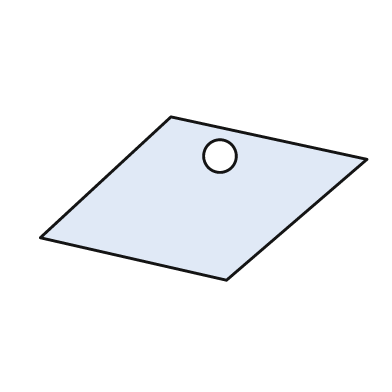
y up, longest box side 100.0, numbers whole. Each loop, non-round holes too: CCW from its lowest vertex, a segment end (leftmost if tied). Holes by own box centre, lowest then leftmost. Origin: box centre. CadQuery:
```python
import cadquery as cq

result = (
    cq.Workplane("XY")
    .moveTo(7.0, -25.0)
    .lineTo(50.0, 12.0)
    .lineTo(-10.0, 25.0)
    .lineTo(-50.0, -12.0)
    .close()
    .moveTo(5.0, 13.0)
    .circle(5.0)
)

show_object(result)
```